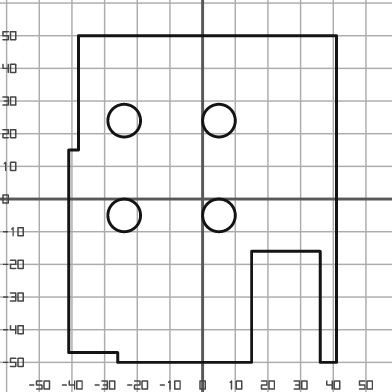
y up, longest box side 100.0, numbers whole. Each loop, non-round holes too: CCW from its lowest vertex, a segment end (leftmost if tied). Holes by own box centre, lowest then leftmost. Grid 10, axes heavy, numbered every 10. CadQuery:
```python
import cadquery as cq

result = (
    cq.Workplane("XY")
    .moveTo(-26.0, -50.0)
    .lineTo(15.0, -50.0)
    .lineTo(15.0, -16.0)
    .lineTo(36.0, -16.0)
    .lineTo(36.0, -50.0)
    .lineTo(41.0, -50.0)
    .lineTo(41.0, 50.0)
    .lineTo(-38.0, 50.0)
    .lineTo(-38.0, 15.0)
    .lineTo(-41.0, 15.0)
    .lineTo(-41.0, -47.0)
    .lineTo(-26.0, -47.0)
    .close()
    .moveTo(-24.0, -5.0)
    .circle(5.0)
    .moveTo(5.0, -5.0)
    .circle(5.0)
    .moveTo(-24.0, 24.0)
    .circle(5.0)
    .moveTo(5.0, 24.0)
    .circle(5.0)
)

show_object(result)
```